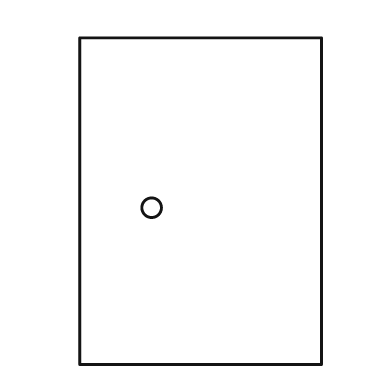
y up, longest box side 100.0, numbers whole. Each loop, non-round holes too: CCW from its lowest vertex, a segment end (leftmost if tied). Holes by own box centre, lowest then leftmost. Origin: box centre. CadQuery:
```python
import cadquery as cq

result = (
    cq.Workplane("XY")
    .moveTo(-37.0, -50.0)
    .lineTo(37.0, -50.0)
    .lineTo(37.0, 50.0)
    .lineTo(-37.0, 50.0)
    .close()
    .moveTo(-15.0, -2.0)
    .circle(3.0)
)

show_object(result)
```